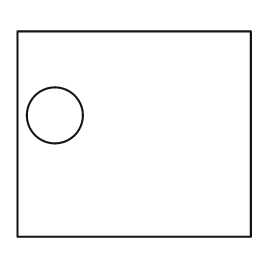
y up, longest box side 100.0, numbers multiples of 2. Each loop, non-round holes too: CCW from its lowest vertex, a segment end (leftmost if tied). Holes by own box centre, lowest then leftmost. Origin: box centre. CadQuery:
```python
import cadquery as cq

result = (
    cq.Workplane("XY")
    .moveTo(-50.0, -44.0)
    .lineTo(50.0, -44.0)
    .lineTo(50.0, 44.0)
    .lineTo(-50.0, 44.0)
    .close()
    .moveTo(-34.0, 8.0)
    .circle(12.0)
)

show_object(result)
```